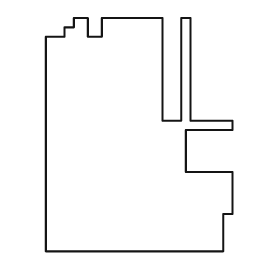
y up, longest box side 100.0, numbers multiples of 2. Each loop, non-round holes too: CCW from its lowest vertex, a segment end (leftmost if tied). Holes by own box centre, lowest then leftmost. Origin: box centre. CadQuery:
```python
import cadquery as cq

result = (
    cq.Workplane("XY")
    .moveTo(-40.0, -50.0)
    .lineTo(36.0, -50.0)
    .lineTo(36.0, -34.0)
    .lineTo(40.0, -34.0)
    .lineTo(40.0, -16.0)
    .lineTo(20.0, -16.0)
    .lineTo(20.0, 2.0)
    .lineTo(40.0, 2.0)
    .lineTo(40.0, 6.0)
    .lineTo(22.0, 6.0)
    .lineTo(22.0, 50.0)
    .lineTo(18.0, 50.0)
    .lineTo(18.0, 6.0)
    .lineTo(10.0, 6.0)
    .lineTo(10.0, 50.0)
    .lineTo(-16.0, 50.0)
    .lineTo(-16.0, 42.0)
    .lineTo(-22.0, 42.0)
    .lineTo(-22.0, 50.0)
    .lineTo(-28.0, 50.0)
    .lineTo(-28.0, 46.0)
    .lineTo(-32.0, 46.0)
    .lineTo(-32.0, 42.0)
    .lineTo(-40.0, 42.0)
    .close()
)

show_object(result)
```